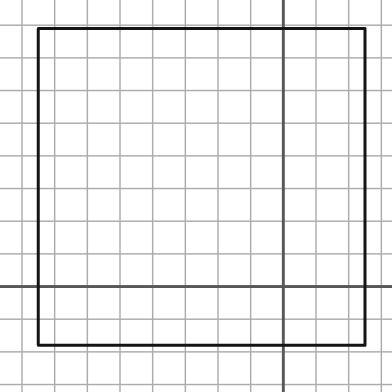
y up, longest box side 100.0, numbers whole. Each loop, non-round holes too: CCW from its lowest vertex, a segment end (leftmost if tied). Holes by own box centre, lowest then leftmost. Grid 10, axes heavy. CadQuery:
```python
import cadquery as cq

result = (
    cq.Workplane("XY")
    .moveTo(-75.0, -18.0)
    .lineTo(25.0, -18.0)
    .lineTo(25.0, 79.0)
    .lineTo(-75.0, 79.0)
    .close()
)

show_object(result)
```